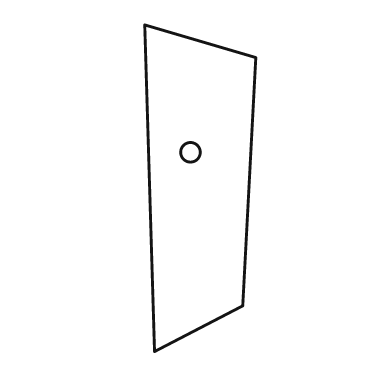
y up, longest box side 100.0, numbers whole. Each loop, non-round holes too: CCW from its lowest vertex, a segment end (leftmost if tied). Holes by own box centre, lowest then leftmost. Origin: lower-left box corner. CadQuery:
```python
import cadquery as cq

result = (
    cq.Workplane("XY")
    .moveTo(3.0, 0.0)
    .lineTo(30.0, 14.0)
    .lineTo(34.0, 90.0)
    .lineTo(0.0, 100.0)
    .close()
    .moveTo(14.0, 61.0)
    .circle(3.0)
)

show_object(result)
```